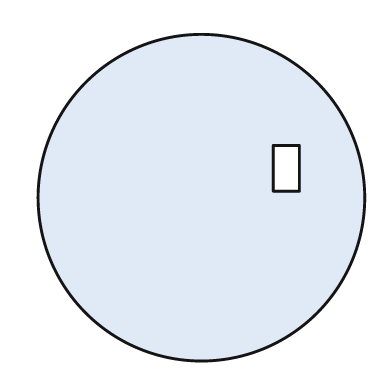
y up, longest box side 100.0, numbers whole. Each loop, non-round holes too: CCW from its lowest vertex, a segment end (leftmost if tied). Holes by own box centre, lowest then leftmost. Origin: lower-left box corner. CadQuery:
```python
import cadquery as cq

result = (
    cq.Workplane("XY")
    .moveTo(50.0, 50.0)
    .circle(50.0)
    .moveTo(72.0, 52.0)
    .lineTo(80.0, 52.0)
    .lineTo(80.0, 66.0)
    .lineTo(72.0, 66.0)
    .close()
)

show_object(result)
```